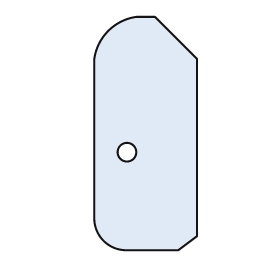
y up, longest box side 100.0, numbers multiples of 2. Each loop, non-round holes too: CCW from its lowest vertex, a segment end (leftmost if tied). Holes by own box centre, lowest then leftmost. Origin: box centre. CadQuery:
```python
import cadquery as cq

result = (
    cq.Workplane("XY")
    .moveTo(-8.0, -50.0)
    .lineTo(14.0, -50.0)
    .lineTo(22.0, -44.0)
    .lineTo(22.0, 32.0)
    .lineTo(4.0, 50.0)
    .lineTo(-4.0, 50.0)
    .threePointArc((-16.0, 44.0), (-22.0, 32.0))
    .lineTo(-22.0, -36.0)
    .threePointArc((-18.0, -46.0), (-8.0, -50.0))
    .close()
    .moveTo(-8.0, -8.0)
    .circle(4.0)
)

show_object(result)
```